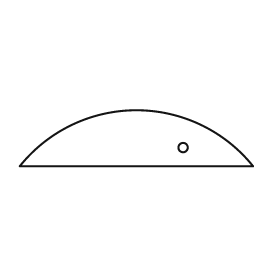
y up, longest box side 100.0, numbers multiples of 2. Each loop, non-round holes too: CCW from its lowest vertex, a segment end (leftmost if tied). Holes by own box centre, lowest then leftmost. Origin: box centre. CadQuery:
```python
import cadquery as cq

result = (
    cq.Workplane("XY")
    .moveTo(-50.0, -12.0)
    .lineTo(50.0, -12.0)
    .threePointArc((0.0, 12.0), (-50.0, -12.0))
    .close()
    .moveTo(20.0, -4.0)
    .circle(2.0)
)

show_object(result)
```